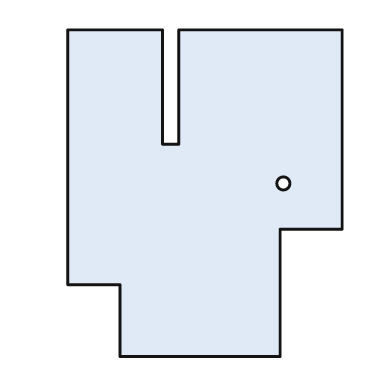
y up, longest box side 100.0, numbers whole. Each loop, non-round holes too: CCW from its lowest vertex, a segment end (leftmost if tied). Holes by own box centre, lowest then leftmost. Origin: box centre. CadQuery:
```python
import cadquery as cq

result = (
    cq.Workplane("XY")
    .moveTo(-26.0, -50.0)
    .lineTo(23.0, -50.0)
    .lineTo(23.0, -11.0)
    .lineTo(42.0, -11.0)
    .lineTo(42.0, 50.0)
    .lineTo(-8.0, 50.0)
    .lineTo(-8.0, 15.0)
    .lineTo(-13.0, 15.0)
    .lineTo(-13.0, 50.0)
    .lineTo(-42.0, 50.0)
    .lineTo(-42.0, -28.0)
    .lineTo(-26.0, -28.0)
    .close()
    .moveTo(24.0, 3.0)
    .circle(2.0)
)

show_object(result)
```